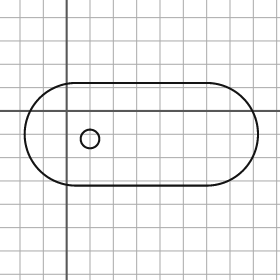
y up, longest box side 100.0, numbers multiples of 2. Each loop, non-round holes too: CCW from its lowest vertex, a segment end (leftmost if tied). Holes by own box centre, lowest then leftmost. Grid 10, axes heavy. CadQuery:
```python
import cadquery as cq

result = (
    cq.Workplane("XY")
    .moveTo(4.0, -32.0)
    .lineTo(60.0, -32.0)
    .threePointArc((82.0, -10.0), (60.0, 12.0))
    .lineTo(4.0, 12.0)
    .threePointArc((-18.0, -10.0), (4.0, -32.0))
    .close()
    .moveTo(10.0, -12.0)
    .circle(4.0)
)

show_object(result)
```